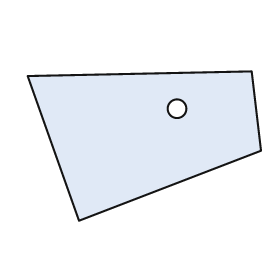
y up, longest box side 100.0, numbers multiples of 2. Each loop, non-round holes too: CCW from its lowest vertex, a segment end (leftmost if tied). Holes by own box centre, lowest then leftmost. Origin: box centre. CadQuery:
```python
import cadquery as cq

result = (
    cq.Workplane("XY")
    .moveTo(-28.0, -32.0)
    .lineTo(50.0, -2.0)
    .lineTo(46.0, 32.0)
    .lineTo(-50.0, 30.0)
    .close()
    .moveTo(14.0, 16.0)
    .circle(4.0)
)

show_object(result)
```